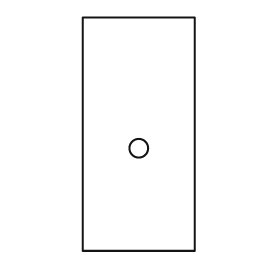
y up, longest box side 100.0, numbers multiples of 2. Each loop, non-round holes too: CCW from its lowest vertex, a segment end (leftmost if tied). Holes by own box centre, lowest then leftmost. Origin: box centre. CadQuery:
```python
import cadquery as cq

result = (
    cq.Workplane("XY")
    .moveTo(-24.0, -50.0)
    .lineTo(24.0, -50.0)
    .lineTo(24.0, 50.0)
    .lineTo(-24.0, 50.0)
    .close()
    .moveTo(0.0, -6.0)
    .circle(4.0)
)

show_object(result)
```